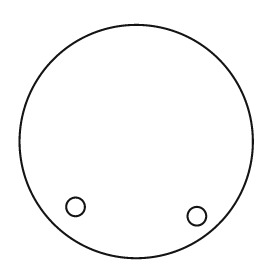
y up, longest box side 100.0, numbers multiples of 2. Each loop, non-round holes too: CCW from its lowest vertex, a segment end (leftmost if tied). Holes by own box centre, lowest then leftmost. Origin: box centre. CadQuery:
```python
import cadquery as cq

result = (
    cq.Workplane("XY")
    .moveTo(0.0, 0.0)
    .circle(50.0)
    .moveTo(26.0, -32.0)
    .circle(4.0)
    .moveTo(-26.0, -28.0)
    .circle(4.0)
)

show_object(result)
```